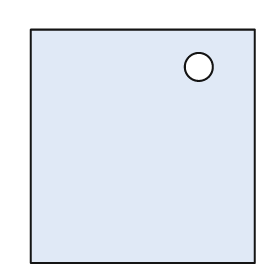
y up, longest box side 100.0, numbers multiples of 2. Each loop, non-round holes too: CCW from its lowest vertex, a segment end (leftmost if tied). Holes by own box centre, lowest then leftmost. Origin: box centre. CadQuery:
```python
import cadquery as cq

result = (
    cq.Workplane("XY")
    .moveTo(-48.0, -50.0)
    .lineTo(48.0, -50.0)
    .lineTo(48.0, 50.0)
    .lineTo(-48.0, 50.0)
    .close()
    .moveTo(24.0, 34.0)
    .circle(6.0)
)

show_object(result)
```